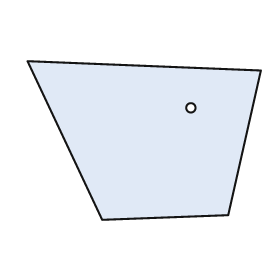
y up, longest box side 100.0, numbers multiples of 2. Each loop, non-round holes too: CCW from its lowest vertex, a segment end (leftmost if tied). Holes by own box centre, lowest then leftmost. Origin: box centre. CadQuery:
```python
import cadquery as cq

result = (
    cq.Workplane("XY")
    .moveTo(-18.0, -34.0)
    .lineTo(36.0, -32.0)
    .lineTo(50.0, 30.0)
    .lineTo(-50.0, 34.0)
    .close()
    .moveTo(20.0, 14.0)
    .circle(2.0)
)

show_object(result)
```